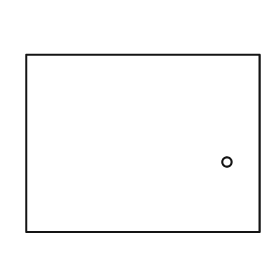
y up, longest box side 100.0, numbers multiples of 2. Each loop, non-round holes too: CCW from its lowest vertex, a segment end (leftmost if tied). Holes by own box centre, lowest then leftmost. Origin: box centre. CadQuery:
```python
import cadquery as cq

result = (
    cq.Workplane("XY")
    .moveTo(-50.0, -38.0)
    .lineTo(50.0, -38.0)
    .lineTo(50.0, 38.0)
    .lineTo(-50.0, 38.0)
    .close()
    .moveTo(36.0, -8.0)
    .circle(2.0)
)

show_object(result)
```